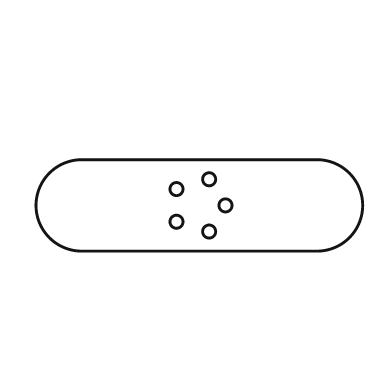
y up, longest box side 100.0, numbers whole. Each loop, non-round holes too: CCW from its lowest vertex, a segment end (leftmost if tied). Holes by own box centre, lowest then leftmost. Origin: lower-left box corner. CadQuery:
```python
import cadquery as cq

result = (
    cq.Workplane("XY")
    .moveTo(14.0, 0.0)
    .lineTo(86.0, 0.0)
    .threePointArc((100.0, 14.0), (86.0, 28.0))
    .lineTo(14.0, 28.0)
    .threePointArc((0.0, 14.0), (14.0, 0.0))
    .close()
    .moveTo(53.0, 6.0)
    .circle(2.0)
    .moveTo(43.0, 9.0)
    .circle(2.0)
    .moveTo(58.0, 14.0)
    .circle(2.0)
    .moveTo(43.0, 19.0)
    .circle(2.0)
    .moveTo(53.0, 22.0)
    .circle(2.0)
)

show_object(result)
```